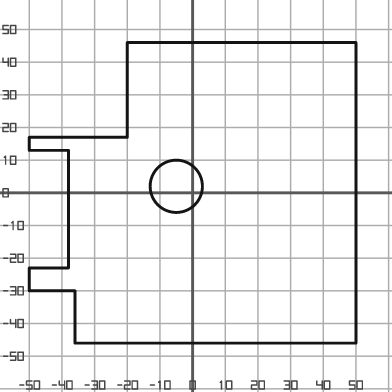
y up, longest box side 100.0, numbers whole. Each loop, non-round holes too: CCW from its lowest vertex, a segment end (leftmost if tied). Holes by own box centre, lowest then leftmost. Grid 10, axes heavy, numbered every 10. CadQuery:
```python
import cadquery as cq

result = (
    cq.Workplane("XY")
    .moveTo(-36.0, -46.0)
    .lineTo(50.0, -46.0)
    .lineTo(50.0, 46.0)
    .lineTo(-20.0, 46.0)
    .lineTo(-20.0, 17.0)
    .lineTo(-50.0, 17.0)
    .lineTo(-50.0, 13.0)
    .lineTo(-38.0, 13.0)
    .lineTo(-38.0, -23.0)
    .lineTo(-50.0, -23.0)
    .lineTo(-50.0, -30.0)
    .lineTo(-36.0, -30.0)
    .close()
    .moveTo(-5.0, 2.0)
    .circle(8.0)
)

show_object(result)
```